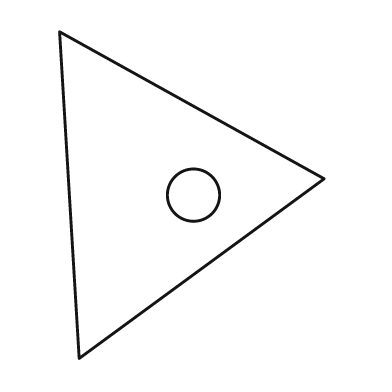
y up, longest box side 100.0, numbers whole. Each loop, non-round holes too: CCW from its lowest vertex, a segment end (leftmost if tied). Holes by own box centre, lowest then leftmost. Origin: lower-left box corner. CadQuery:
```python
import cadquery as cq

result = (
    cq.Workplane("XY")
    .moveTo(6.0, 0.0)
    .lineTo(81.0, 55.0)
    .lineTo(0.0, 100.0)
    .close()
    .moveTo(41.0, 50.0)
    .circle(8.0)
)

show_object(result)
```